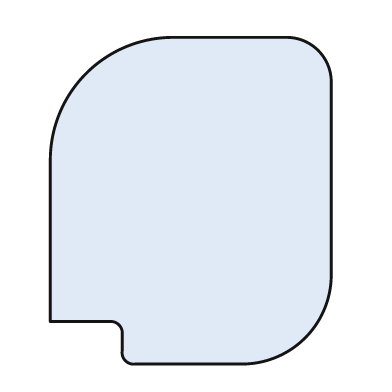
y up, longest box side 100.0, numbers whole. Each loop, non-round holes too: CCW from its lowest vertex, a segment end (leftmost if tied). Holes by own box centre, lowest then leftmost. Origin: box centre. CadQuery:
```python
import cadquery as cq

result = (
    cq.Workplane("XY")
    .moveTo(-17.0, -50.0)
    .lineTo(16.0, -50.0)
    .threePointArc((35.0, -42.0), (43.0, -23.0))
    .lineTo(43.0, 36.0)
    .threePointArc((39.0, 46.0), (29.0, 50.0))
    .lineTo(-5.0, 50.0)
    .threePointArc((-32.0, 39.0), (-43.0, 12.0))
    .lineTo(-43.0, -37.0)
    .lineTo(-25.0, -37.0)
    .threePointArc((-22.0, -38.0), (-21.0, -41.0))
    .lineTo(-21.0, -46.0)
    .threePointArc((-20.0, -49.0), (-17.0, -50.0))
    .close()
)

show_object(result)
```